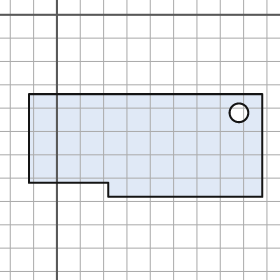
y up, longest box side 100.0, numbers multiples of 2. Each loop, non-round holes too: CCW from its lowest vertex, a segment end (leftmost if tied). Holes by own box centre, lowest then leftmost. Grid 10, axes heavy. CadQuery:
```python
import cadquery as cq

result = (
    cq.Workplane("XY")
    .moveTo(22.0, -78.0)
    .lineTo(88.0, -78.0)
    .lineTo(88.0, -34.0)
    .lineTo(-12.0, -34.0)
    .lineTo(-12.0, -72.0)
    .lineTo(22.0, -72.0)
    .close()
    .moveTo(78.0, -42.0)
    .circle(4.0)
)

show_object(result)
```